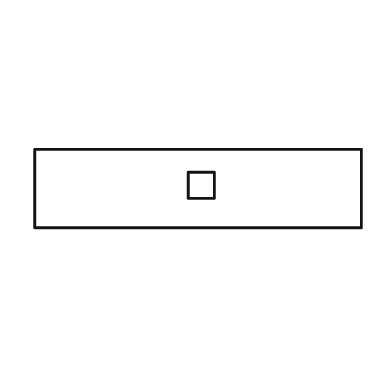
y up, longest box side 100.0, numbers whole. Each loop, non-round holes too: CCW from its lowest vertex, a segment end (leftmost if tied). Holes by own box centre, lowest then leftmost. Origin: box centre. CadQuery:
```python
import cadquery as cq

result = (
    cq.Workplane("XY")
    .moveTo(-50.0, -12.0)
    .lineTo(50.0, -12.0)
    .lineTo(50.0, 12.0)
    .lineTo(-50.0, 12.0)
    .close()
    .moveTo(-3.0, -3.0)
    .lineTo(5.0, -3.0)
    .lineTo(5.0, 5.0)
    .lineTo(-3.0, 5.0)
    .close()
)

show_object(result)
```